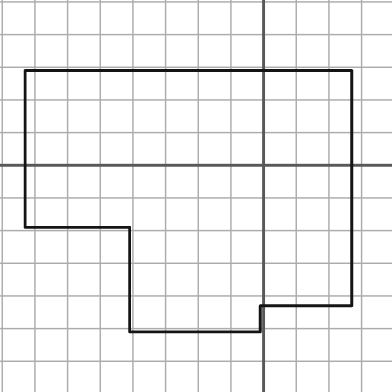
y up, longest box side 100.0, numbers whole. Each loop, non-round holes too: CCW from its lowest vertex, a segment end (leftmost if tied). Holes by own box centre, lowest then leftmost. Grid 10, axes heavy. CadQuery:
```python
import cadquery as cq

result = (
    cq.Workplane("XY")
    .moveTo(-41.0, -51.0)
    .lineTo(-1.0, -51.0)
    .lineTo(-1.0, -43.0)
    .lineTo(27.0, -43.0)
    .lineTo(27.0, 29.0)
    .lineTo(-73.0, 29.0)
    .lineTo(-73.0, -19.0)
    .lineTo(-41.0, -19.0)
    .close()
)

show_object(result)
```